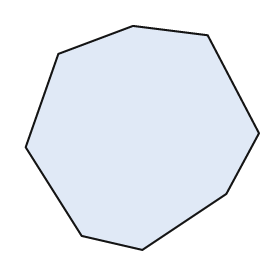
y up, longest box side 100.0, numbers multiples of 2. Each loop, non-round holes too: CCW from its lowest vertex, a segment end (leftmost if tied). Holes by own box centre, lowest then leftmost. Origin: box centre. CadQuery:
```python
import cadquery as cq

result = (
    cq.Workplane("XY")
    .moveTo(0.0, -48.0)
    .lineTo(36.0, -24.0)
    .lineTo(50.0, 2.0)
    .lineTo(28.0, 44.0)
    .lineTo(-4.0, 48.0)
    .lineTo(-36.0, 36.0)
    .lineTo(-50.0, -4.0)
    .lineTo(-26.0, -42.0)
    .close()
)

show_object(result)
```